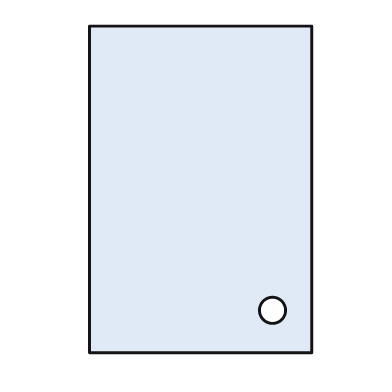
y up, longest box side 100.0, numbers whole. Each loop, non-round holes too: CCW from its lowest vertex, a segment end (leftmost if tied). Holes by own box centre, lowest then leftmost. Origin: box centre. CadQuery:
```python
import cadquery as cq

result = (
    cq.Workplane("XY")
    .moveTo(-34.0, -50.0)
    .lineTo(34.0, -50.0)
    .lineTo(34.0, 50.0)
    .lineTo(-34.0, 50.0)
    .close()
    .moveTo(22.0, -37.0)
    .circle(4.0)
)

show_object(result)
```